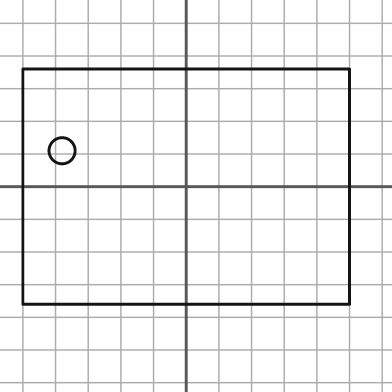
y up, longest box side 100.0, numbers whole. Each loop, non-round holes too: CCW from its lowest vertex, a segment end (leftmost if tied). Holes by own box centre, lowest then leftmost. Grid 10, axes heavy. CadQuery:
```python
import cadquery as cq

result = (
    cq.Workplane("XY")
    .moveTo(-50.0, -36.0)
    .lineTo(50.0, -36.0)
    .lineTo(50.0, 36.0)
    .lineTo(-50.0, 36.0)
    .close()
    .moveTo(-38.0, 11.0)
    .circle(4.0)
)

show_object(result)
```